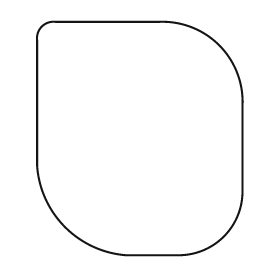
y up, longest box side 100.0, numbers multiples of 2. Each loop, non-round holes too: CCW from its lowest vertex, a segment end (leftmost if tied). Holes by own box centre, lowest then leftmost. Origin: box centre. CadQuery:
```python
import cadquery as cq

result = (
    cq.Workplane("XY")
    .moveTo(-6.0, -50.0)
    .lineTo(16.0, -50.0)
    .threePointArc((36.0, -42.0), (44.0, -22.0))
    .lineTo(44.0, 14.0)
    .threePointArc((34.0, 40.0), (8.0, 50.0))
    .lineTo(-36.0, 50.0)
    .threePointArc((-42.0, 48.0), (-44.0, 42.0))
    .lineTo(-44.0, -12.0)
    .threePointArc((-32.0, -38.0), (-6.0, -50.0))
    .close()
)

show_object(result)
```